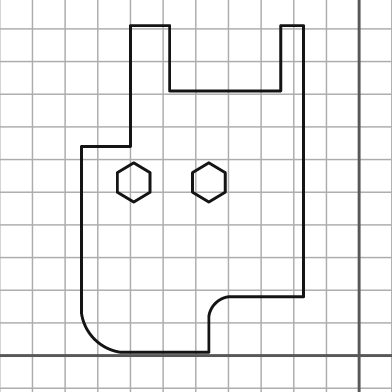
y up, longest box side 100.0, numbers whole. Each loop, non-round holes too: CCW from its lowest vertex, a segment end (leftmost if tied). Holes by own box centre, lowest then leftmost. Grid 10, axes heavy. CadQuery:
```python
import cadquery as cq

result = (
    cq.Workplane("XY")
    .moveTo(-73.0, 1.0)
    .lineTo(-46.0, 1.0)
    .lineTo(-46.0, 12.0)
    .threePointArc((-44.0, 16.0), (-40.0, 18.0))
    .lineTo(-17.0, 18.0)
    .lineTo(-17.0, 101.0)
    .lineTo(-24.0, 101.0)
    .lineTo(-24.0, 81.0)
    .lineTo(-58.0, 81.0)
    .lineTo(-58.0, 101.0)
    .lineTo(-70.0, 101.0)
    .lineTo(-70.0, 64.0)
    .lineTo(-85.0, 64.0)
    .lineTo(-85.0, 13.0)
    .threePointArc((-81.0, 5.0), (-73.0, 1.0))
    .close()
    .moveTo(-69.0, 47.0)
    .lineTo(-64.0, 50.0)
    .lineTo(-64.0, 56.0)
    .lineTo(-69.0, 59.0)
    .lineTo(-74.0, 56.0)
    .lineTo(-74.0, 50.0)
    .close()
    .moveTo(-46.0, 47.0)
    .lineTo(-41.0, 50.0)
    .lineTo(-41.0, 56.0)
    .lineTo(-46.0, 59.0)
    .lineTo(-51.0, 56.0)
    .lineTo(-51.0, 50.0)
    .close()
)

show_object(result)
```